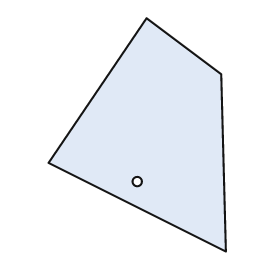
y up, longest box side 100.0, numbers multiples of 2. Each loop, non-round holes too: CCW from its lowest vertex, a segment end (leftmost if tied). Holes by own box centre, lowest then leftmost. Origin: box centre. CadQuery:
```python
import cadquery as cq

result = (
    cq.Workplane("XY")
    .moveTo(38.0, -50.0)
    .lineTo(36.0, 26.0)
    .lineTo(4.0, 50.0)
    .lineTo(-38.0, -12.0)
    .close()
    .moveTo(0.0, -20.0)
    .circle(2.0)
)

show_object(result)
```